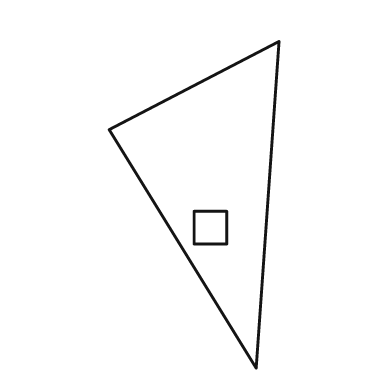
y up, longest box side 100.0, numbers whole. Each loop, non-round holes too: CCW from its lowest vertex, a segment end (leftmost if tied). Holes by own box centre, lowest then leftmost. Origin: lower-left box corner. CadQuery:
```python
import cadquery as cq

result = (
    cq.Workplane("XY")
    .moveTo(45.0, 0.0)
    .lineTo(52.0, 100.0)
    .lineTo(0.0, 73.0)
    .close()
    .moveTo(26.0, 38.0)
    .lineTo(36.0, 38.0)
    .lineTo(36.0, 48.0)
    .lineTo(26.0, 48.0)
    .close()
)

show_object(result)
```